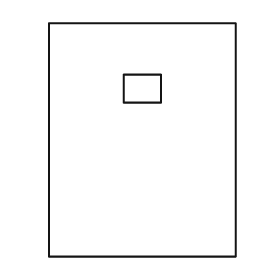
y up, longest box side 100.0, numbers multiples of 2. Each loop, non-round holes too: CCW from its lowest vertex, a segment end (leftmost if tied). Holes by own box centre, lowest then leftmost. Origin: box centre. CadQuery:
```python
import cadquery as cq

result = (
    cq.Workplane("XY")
    .moveTo(-40.0, -50.0)
    .lineTo(40.0, -50.0)
    .lineTo(40.0, 50.0)
    .lineTo(-40.0, 50.0)
    .close()
    .moveTo(-8.0, 16.0)
    .lineTo(8.0, 16.0)
    .lineTo(8.0, 28.0)
    .lineTo(-8.0, 28.0)
    .close()
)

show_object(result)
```